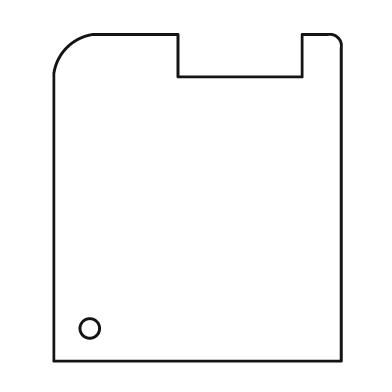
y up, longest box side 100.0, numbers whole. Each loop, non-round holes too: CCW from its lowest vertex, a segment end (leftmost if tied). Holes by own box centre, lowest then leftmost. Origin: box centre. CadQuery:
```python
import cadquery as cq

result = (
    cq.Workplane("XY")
    .moveTo(-44.0, -50.0)
    .lineTo(44.0, -50.0)
    .lineTo(44.0, 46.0)
    .threePointArc((43.0, 49.0), (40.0, 50.0))
    .lineTo(32.0, 50.0)
    .lineTo(32.0, 37.0)
    .lineTo(-6.0, 37.0)
    .lineTo(-6.0, 50.0)
    .lineTo(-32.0, 50.0)
    .threePointArc((-40.0, 46.0), (-44.0, 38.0))
    .close()
    .moveTo(-33.0, -40.0)
    .circle(3.0)
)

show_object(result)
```